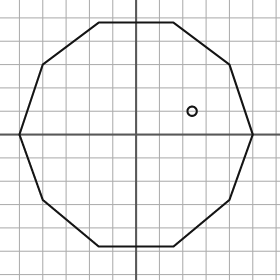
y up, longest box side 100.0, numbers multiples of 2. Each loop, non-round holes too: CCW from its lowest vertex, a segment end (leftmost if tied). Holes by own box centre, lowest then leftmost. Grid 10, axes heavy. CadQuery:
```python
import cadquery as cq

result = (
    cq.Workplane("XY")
    .moveTo(-16.0, -48.0)
    .lineTo(16.0, -48.0)
    .lineTo(40.0, -28.0)
    .lineTo(50.0, 0.0)
    .lineTo(40.0, 30.0)
    .lineTo(16.0, 48.0)
    .lineTo(-16.0, 48.0)
    .lineTo(-40.0, 30.0)
    .lineTo(-50.0, 0.0)
    .lineTo(-40.0, -28.0)
    .close()
    .moveTo(24.0, 10.0)
    .circle(2.0)
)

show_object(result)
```